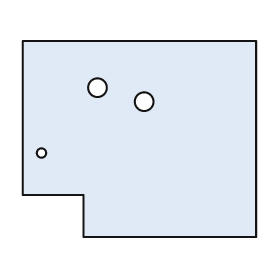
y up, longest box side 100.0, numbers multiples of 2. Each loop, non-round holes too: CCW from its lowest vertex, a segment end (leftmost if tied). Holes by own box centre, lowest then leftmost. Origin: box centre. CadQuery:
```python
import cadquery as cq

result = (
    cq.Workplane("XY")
    .moveTo(-24.0, -42.0)
    .lineTo(50.0, -42.0)
    .lineTo(50.0, 42.0)
    .lineTo(-50.0, 42.0)
    .lineTo(-50.0, -24.0)
    .lineTo(-24.0, -24.0)
    .close()
    .moveTo(-42.0, -6.0)
    .circle(2.0)
    .moveTo(2.0, 16.0)
    .circle(4.0)
    .moveTo(-18.0, 22.0)
    .circle(4.0)
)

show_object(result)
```